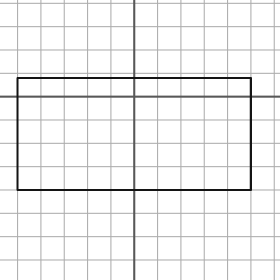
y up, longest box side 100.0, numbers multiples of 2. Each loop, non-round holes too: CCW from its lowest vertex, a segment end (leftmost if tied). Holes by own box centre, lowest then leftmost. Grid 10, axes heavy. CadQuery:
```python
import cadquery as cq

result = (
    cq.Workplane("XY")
    .moveTo(-50.0, -40.0)
    .lineTo(50.0, -40.0)
    .lineTo(50.0, 8.0)
    .lineTo(-50.0, 8.0)
    .close()
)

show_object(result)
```